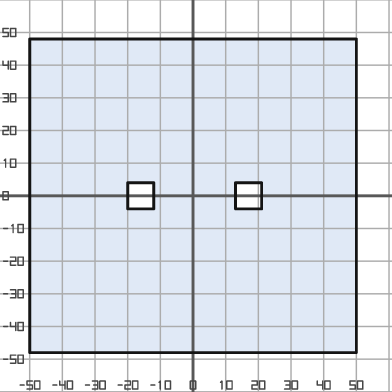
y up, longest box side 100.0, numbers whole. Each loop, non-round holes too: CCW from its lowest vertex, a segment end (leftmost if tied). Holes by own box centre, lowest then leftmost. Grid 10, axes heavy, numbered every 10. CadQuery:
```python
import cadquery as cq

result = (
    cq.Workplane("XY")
    .moveTo(-50.0, -48.0)
    .lineTo(50.0, -48.0)
    .lineTo(50.0, 48.0)
    .lineTo(-50.0, 48.0)
    .close()
    .moveTo(-20.0, -4.0)
    .lineTo(-12.0, -4.0)
    .lineTo(-12.0, 4.0)
    .lineTo(-20.0, 4.0)
    .close()
    .moveTo(13.0, -4.0)
    .lineTo(21.0, -4.0)
    .lineTo(21.0, 4.0)
    .lineTo(13.0, 4.0)
    .close()
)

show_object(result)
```